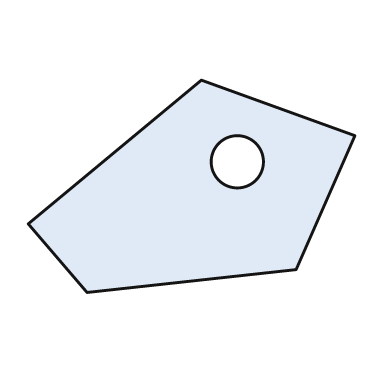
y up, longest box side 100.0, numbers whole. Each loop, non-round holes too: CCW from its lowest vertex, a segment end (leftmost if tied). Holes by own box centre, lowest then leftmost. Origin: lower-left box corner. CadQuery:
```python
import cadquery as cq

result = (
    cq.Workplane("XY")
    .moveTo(18.0, 0.0)
    .lineTo(82.0, 7.0)
    .lineTo(100.0, 48.0)
    .lineTo(53.0, 65.0)
    .lineTo(0.0, 21.0)
    .close()
    .moveTo(64.0, 40.0)
    .circle(8.0)
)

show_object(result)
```